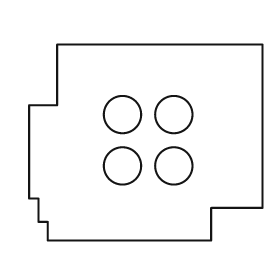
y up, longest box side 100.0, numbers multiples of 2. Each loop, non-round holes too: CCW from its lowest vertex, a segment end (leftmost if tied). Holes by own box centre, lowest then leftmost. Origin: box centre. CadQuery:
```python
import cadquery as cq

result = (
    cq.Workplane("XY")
    .moveTo(-42.0, -42.0)
    .lineTo(28.0, -42.0)
    .lineTo(28.0, -28.0)
    .lineTo(50.0, -28.0)
    .lineTo(50.0, 42.0)
    .lineTo(-38.0, 42.0)
    .lineTo(-38.0, 16.0)
    .lineTo(-50.0, 16.0)
    .lineTo(-50.0, -24.0)
    .lineTo(-46.0, -24.0)
    .lineTo(-46.0, -34.0)
    .lineTo(-42.0, -34.0)
    .close()
    .moveTo(-10.0, -10.0)
    .circle(8.0)
    .moveTo(12.0, -10.0)
    .circle(8.0)
    .moveTo(-10.0, 12.0)
    .circle(8.0)
    .moveTo(12.0, 12.0)
    .circle(8.0)
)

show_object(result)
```